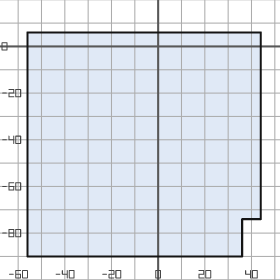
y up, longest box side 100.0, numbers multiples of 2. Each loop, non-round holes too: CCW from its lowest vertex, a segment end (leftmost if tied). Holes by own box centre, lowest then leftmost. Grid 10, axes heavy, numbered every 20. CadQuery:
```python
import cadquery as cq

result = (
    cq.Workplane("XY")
    .moveTo(-56.0, -90.0)
    .lineTo(36.0, -90.0)
    .lineTo(36.0, -74.0)
    .lineTo(44.0, -74.0)
    .lineTo(44.0, 6.0)
    .lineTo(-56.0, 6.0)
    .close()
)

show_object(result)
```